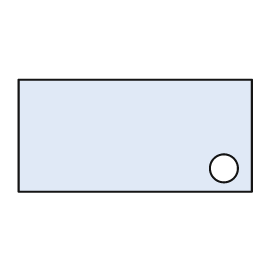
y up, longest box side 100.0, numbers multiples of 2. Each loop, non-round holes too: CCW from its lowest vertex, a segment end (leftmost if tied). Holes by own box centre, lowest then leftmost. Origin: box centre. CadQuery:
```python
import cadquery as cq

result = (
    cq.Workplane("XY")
    .moveTo(-50.0, -24.0)
    .lineTo(50.0, -24.0)
    .lineTo(50.0, 24.0)
    .lineTo(-50.0, 24.0)
    .close()
    .moveTo(38.0, -14.0)
    .circle(6.0)
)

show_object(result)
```